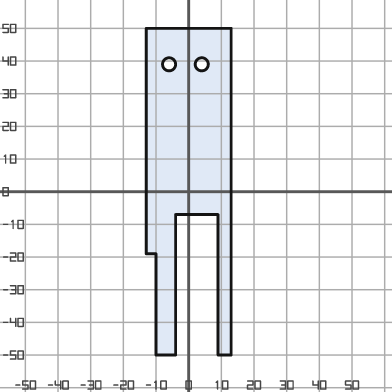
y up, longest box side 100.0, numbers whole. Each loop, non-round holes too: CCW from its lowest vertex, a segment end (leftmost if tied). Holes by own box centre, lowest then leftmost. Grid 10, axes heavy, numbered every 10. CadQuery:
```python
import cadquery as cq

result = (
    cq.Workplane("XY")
    .moveTo(-10.0, -50.0)
    .lineTo(-4.0, -50.0)
    .lineTo(-4.0, -7.0)
    .lineTo(9.0, -7.0)
    .lineTo(9.0, -50.0)
    .lineTo(13.0, -50.0)
    .lineTo(13.0, 50.0)
    .lineTo(-13.0, 50.0)
    .lineTo(-13.0, -19.0)
    .lineTo(-10.0, -19.0)
    .close()
    .moveTo(-6.0, 39.0)
    .circle(2.0)
    .moveTo(4.0, 39.0)
    .circle(2.0)
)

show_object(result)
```